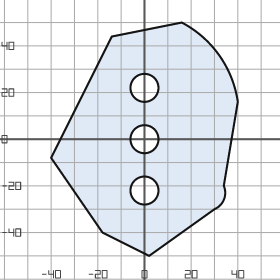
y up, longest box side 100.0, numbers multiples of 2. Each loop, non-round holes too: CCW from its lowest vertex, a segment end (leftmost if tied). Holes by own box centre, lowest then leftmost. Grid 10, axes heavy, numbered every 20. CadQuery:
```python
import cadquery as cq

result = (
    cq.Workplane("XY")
    .moveTo(2.0, -50.0)
    .lineTo(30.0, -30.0)
    .threePointArc((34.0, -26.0), (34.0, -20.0))
    .lineTo(40.0, 16.0)
    .threePointArc((32.0, 36.0), (16.0, 50.0))
    .lineTo(-14.0, 44.0)
    .lineTo(-40.0, -8.0)
    .lineTo(-18.0, -40.0)
    .close()
    .moveTo(0.0, -22.0)
    .circle(6.0)
    .moveTo(0.0, 0.0)
    .circle(6.0)
    .moveTo(0.0, 22.0)
    .circle(6.0)
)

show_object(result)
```